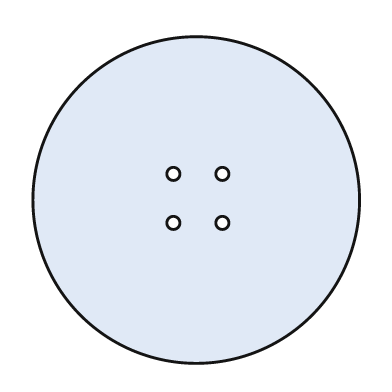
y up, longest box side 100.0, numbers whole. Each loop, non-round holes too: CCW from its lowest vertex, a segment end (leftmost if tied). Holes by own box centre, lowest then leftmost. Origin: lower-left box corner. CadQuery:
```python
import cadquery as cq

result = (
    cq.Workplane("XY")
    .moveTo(50.0, 50.0)
    .circle(50.0)
    .moveTo(43.0, 43.0)
    .circle(2.0)
    .moveTo(58.0, 43.0)
    .circle(2.0)
    .moveTo(43.0, 58.0)
    .circle(2.0)
    .moveTo(58.0, 58.0)
    .circle(2.0)
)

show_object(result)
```